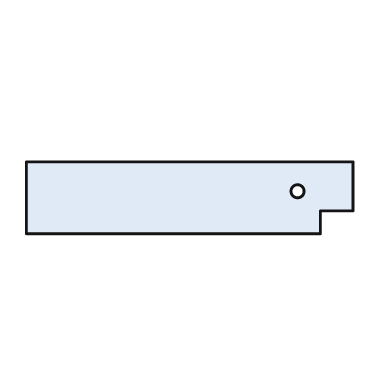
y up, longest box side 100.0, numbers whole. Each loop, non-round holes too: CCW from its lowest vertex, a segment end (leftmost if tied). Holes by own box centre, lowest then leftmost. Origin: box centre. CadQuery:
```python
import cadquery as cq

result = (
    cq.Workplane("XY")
    .moveTo(-50.0, -11.0)
    .lineTo(40.0, -11.0)
    .lineTo(40.0, -4.0)
    .lineTo(50.0, -4.0)
    .lineTo(50.0, 11.0)
    .lineTo(-50.0, 11.0)
    .close()
    .moveTo(33.0, 2.0)
    .circle(2.0)
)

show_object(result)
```